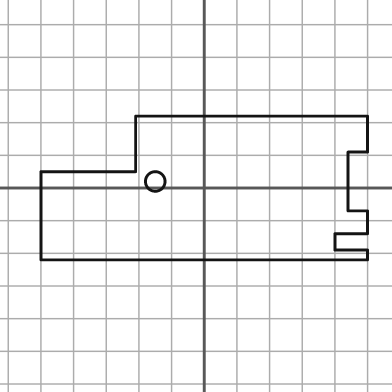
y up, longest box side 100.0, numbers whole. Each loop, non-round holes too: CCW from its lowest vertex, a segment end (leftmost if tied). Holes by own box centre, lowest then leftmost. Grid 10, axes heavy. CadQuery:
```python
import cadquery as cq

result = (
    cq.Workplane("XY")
    .moveTo(-50.0, -22.0)
    .lineTo(50.0, -22.0)
    .lineTo(50.0, -19.0)
    .lineTo(40.0, -19.0)
    .lineTo(40.0, -14.0)
    .lineTo(50.0, -14.0)
    .lineTo(50.0, -7.0)
    .lineTo(44.0, -7.0)
    .lineTo(44.0, 11.0)
    .lineTo(50.0, 11.0)
    .lineTo(50.0, 22.0)
    .lineTo(-21.0, 22.0)
    .lineTo(-21.0, 5.0)
    .lineTo(-50.0, 5.0)
    .close()
    .moveTo(-15.0, 2.0)
    .circle(3.0)
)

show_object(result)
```